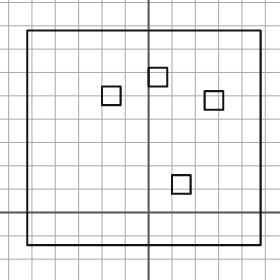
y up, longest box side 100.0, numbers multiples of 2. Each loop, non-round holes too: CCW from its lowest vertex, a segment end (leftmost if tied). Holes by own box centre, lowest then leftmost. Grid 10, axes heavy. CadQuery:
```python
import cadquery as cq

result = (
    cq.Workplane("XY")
    .moveTo(-52.0, -14.0)
    .lineTo(48.0, -14.0)
    .lineTo(48.0, 78.0)
    .lineTo(-52.0, 78.0)
    .close()
    .moveTo(10.0, 8.0)
    .lineTo(18.0, 8.0)
    .lineTo(18.0, 16.0)
    .lineTo(10.0, 16.0)
    .close()
    .moveTo(24.0, 44.0)
    .lineTo(32.0, 44.0)
    .lineTo(32.0, 52.0)
    .lineTo(24.0, 52.0)
    .close()
    .moveTo(-20.0, 46.0)
    .lineTo(-12.0, 46.0)
    .lineTo(-12.0, 54.0)
    .lineTo(-20.0, 54.0)
    .close()
    .moveTo(0.0, 54.0)
    .lineTo(8.0, 54.0)
    .lineTo(8.0, 62.0)
    .lineTo(0.0, 62.0)
    .close()
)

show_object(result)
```